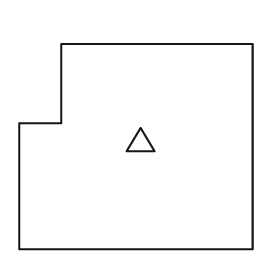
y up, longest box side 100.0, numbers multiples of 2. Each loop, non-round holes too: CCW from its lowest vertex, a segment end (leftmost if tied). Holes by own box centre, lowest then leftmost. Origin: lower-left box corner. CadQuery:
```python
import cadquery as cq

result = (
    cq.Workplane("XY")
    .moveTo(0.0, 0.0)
    .lineTo(100.0, 0.0)
    .lineTo(100.0, 88.0)
    .lineTo(18.0, 88.0)
    .lineTo(18.0, 54.0)
    .lineTo(0.0, 54.0)
    .close()
    .moveTo(46.0, 42.0)
    .lineTo(58.0, 42.0)
    .lineTo(52.0, 52.0)
    .close()
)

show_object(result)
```